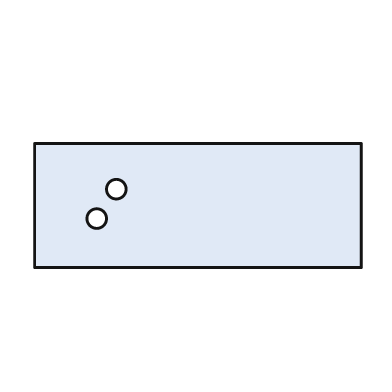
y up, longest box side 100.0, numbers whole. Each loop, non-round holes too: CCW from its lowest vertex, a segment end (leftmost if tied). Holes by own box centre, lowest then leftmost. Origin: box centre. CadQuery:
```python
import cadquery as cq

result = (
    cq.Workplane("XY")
    .moveTo(-50.0, -19.0)
    .lineTo(50.0, -19.0)
    .lineTo(50.0, 19.0)
    .lineTo(-50.0, 19.0)
    .close()
    .moveTo(-31.0, -4.0)
    .circle(3.0)
    .moveTo(-25.0, 5.0)
    .circle(3.0)
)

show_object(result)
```